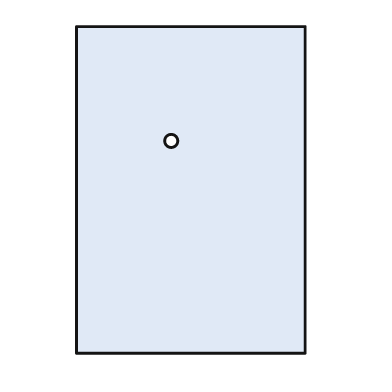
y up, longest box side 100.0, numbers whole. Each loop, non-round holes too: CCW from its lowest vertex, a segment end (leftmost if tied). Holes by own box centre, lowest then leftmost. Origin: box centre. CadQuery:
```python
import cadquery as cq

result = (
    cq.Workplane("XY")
    .moveTo(-35.0, -50.0)
    .lineTo(35.0, -50.0)
    .lineTo(35.0, 50.0)
    .lineTo(-35.0, 50.0)
    .close()
    .moveTo(-6.0, 15.0)
    .circle(2.0)
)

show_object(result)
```